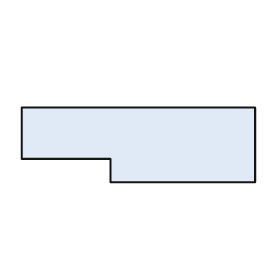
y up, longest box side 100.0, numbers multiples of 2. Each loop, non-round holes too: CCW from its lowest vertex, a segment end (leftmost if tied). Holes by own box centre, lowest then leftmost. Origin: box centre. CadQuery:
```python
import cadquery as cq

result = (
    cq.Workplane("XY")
    .moveTo(-12.0, -16.0)
    .lineTo(50.0, -16.0)
    .lineTo(50.0, 16.0)
    .lineTo(-50.0, 16.0)
    .lineTo(-50.0, -6.0)
    .lineTo(-12.0, -6.0)
    .close()
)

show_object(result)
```